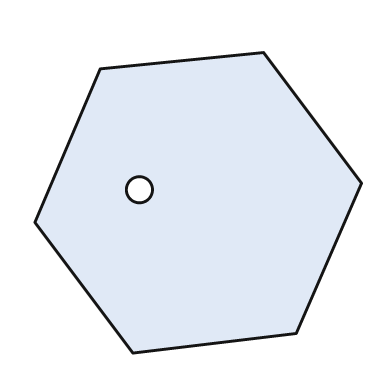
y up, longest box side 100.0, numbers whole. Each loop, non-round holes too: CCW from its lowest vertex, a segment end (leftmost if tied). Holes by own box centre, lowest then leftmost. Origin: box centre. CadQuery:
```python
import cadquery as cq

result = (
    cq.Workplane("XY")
    .moveTo(-20.0, -46.0)
    .lineTo(30.0, -40.0)
    .lineTo(50.0, 6.0)
    .lineTo(20.0, 46.0)
    .lineTo(-30.0, 41.0)
    .lineTo(-50.0, -6.0)
    .close()
    .moveTo(-18.0, 4.0)
    .circle(4.0)
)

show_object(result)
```